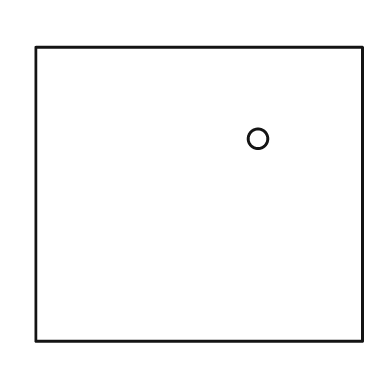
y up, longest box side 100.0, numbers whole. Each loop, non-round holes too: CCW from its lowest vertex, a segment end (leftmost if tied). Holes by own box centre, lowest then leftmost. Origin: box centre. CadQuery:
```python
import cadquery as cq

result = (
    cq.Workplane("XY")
    .moveTo(-50.0, -45.0)
    .lineTo(50.0, -45.0)
    .lineTo(50.0, 45.0)
    .lineTo(-50.0, 45.0)
    .close()
    .moveTo(18.0, 17.0)
    .circle(3.0)
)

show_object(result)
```